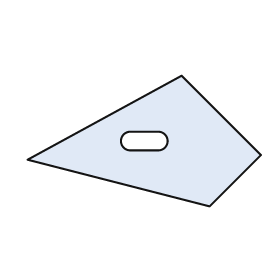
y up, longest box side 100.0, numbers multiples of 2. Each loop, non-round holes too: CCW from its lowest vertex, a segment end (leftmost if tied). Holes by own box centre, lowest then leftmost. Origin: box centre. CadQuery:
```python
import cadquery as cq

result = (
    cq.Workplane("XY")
    .moveTo(28.0, -28.0)
    .lineTo(50.0, -6.0)
    .lineTo(16.0, 28.0)
    .lineTo(-50.0, -8.0)
    .close()
    .moveTo(-6.0, -4.0)
    .lineTo(6.0, -4.0)
    .threePointArc((10.0, 0.0), (6.0, 4.0))
    .lineTo(-6.0, 4.0)
    .threePointArc((-10.0, 0.0), (-6.0, -4.0))
    .close()
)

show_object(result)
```